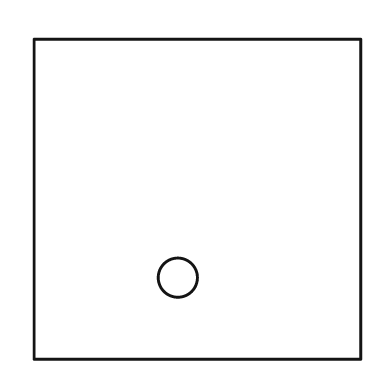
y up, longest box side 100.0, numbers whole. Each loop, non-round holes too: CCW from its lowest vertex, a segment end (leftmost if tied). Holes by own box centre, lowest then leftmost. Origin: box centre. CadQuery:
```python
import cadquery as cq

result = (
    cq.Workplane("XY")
    .moveTo(-50.0, -49.0)
    .lineTo(50.0, -49.0)
    .lineTo(50.0, 49.0)
    .lineTo(-50.0, 49.0)
    .close()
    .moveTo(-6.0, -24.0)
    .circle(6.0)
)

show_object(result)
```